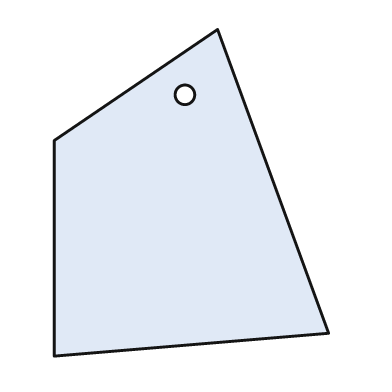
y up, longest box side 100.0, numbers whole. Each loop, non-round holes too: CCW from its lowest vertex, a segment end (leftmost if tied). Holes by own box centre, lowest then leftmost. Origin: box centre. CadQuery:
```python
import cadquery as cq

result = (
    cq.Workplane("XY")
    .moveTo(-42.0, -50.0)
    .lineTo(42.0, -43.0)
    .lineTo(8.0, 50.0)
    .lineTo(-42.0, 16.0)
    .close()
    .moveTo(-2.0, 30.0)
    .circle(3.0)
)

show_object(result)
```